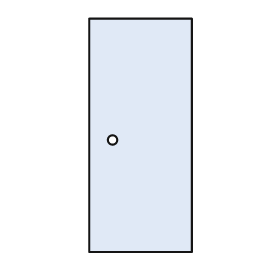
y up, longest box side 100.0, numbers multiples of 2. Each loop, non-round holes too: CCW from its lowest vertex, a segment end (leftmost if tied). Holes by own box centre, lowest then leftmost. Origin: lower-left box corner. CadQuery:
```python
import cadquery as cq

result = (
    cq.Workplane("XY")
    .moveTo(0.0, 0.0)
    .lineTo(44.0, 0.0)
    .lineTo(44.0, 100.0)
    .lineTo(0.0, 100.0)
    .close()
    .moveTo(10.0, 48.0)
    .circle(2.0)
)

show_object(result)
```